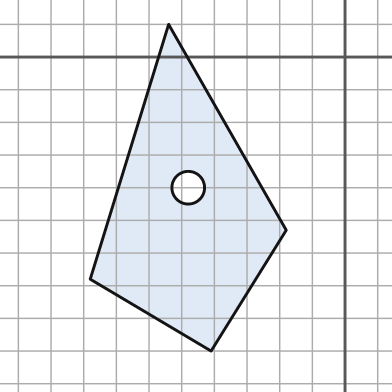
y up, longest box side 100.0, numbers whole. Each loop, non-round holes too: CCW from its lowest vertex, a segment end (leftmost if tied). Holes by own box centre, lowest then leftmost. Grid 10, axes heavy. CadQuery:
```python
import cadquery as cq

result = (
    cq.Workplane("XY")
    .moveTo(-41.0, -90.0)
    .lineTo(-18.0, -53.0)
    .lineTo(-54.0, 10.0)
    .lineTo(-78.0, -68.0)
    .close()
    .moveTo(-48.0, -40.0)
    .circle(5.0)
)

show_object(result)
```